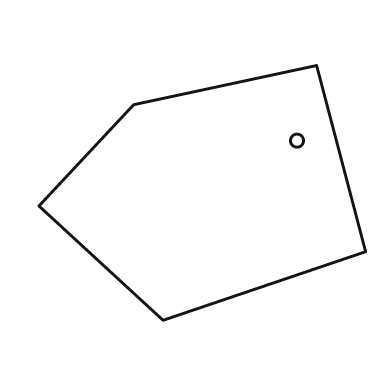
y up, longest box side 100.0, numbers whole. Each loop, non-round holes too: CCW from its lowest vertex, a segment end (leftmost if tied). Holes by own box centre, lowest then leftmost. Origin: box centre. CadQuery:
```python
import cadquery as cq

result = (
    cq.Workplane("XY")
    .moveTo(-12.0, -39.0)
    .lineTo(50.0, -18.0)
    .lineTo(35.0, 39.0)
    .lineTo(-21.0, 27.0)
    .lineTo(-50.0, -4.0)
    .close()
    .moveTo(29.0, 16.0)
    .circle(2.0)
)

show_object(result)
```